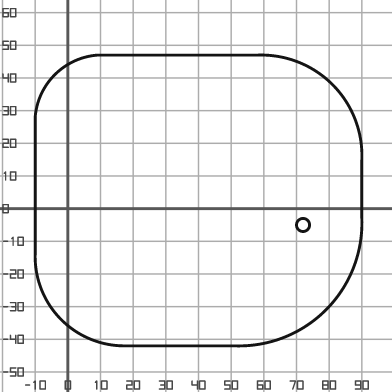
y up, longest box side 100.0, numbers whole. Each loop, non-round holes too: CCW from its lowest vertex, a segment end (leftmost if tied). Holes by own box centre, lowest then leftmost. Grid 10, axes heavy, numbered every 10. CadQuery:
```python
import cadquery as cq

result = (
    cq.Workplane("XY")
    .moveTo(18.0, -42.0)
    .lineTo(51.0, -42.0)
    .threePointArc((79.0, -31.0), (90.0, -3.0))
    .lineTo(90.0, 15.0)
    .threePointArc((81.0, 38.0), (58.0, 47.0))
    .lineTo(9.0, 47.0)
    .threePointArc((-4.0, 41.0), (-10.0, 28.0))
    .lineTo(-10.0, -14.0)
    .threePointArc((-2.0, -34.0), (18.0, -42.0))
    .close()
    .moveTo(72.0, -5.0)
    .circle(2.0)
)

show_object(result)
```